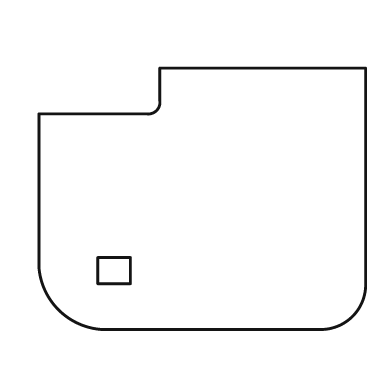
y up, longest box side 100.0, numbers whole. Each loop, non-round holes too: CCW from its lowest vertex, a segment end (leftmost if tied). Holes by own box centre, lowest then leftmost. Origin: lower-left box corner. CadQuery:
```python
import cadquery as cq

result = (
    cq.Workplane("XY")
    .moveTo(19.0, 0.0)
    .lineTo(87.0, 0.0)
    .threePointArc((96.0, 4.0), (100.0, 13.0))
    .lineTo(100.0, 80.0)
    .lineTo(37.0, 80.0)
    .lineTo(37.0, 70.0)
    .threePointArc((36.0, 67.0), (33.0, 66.0))
    .lineTo(0.0, 66.0)
    .lineTo(0.0, 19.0)
    .threePointArc((6.0, 6.0), (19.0, 0.0))
    .close()
    .moveTo(18.0, 14.0)
    .lineTo(28.0, 14.0)
    .lineTo(28.0, 22.0)
    .lineTo(18.0, 22.0)
    .close()
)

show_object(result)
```